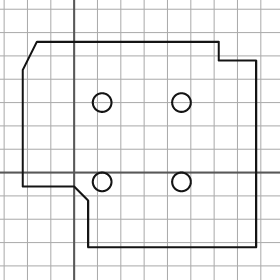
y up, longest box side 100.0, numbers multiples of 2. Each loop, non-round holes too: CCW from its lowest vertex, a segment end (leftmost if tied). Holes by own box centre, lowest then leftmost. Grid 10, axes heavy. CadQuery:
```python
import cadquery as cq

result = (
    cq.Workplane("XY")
    .moveTo(6.0, -32.0)
    .lineTo(78.0, -32.0)
    .lineTo(78.0, 48.0)
    .lineTo(62.0, 48.0)
    .lineTo(62.0, 56.0)
    .lineTo(-16.0, 56.0)
    .lineTo(-22.0, 44.0)
    .lineTo(-22.0, -6.0)
    .lineTo(0.0, -6.0)
    .lineTo(6.0, -12.0)
    .close()
    .moveTo(12.0, -4.0)
    .circle(4.0)
    .moveTo(46.0, -4.0)
    .circle(4.0)
    .moveTo(12.0, 30.0)
    .circle(4.0)
    .moveTo(46.0, 30.0)
    .circle(4.0)
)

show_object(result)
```